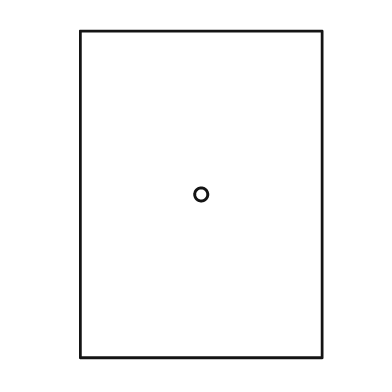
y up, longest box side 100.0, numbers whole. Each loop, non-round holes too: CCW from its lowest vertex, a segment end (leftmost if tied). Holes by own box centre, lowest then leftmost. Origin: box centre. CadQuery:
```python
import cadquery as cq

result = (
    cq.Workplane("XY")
    .moveTo(-37.0, -50.0)
    .lineTo(37.0, -50.0)
    .lineTo(37.0, 50.0)
    .lineTo(-37.0, 50.0)
    .close()
    .moveTo(0.0, 0.0)
    .circle(2.0)
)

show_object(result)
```